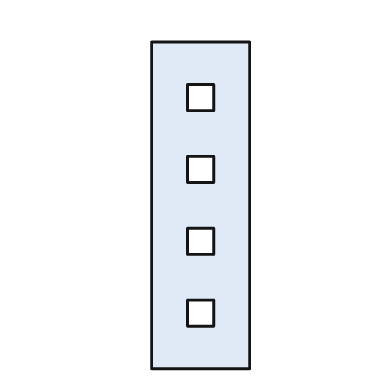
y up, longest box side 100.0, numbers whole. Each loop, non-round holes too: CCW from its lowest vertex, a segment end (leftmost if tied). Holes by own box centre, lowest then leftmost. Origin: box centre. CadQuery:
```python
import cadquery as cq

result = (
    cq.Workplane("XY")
    .moveTo(-15.0, -50.0)
    .lineTo(15.0, -50.0)
    .lineTo(15.0, 50.0)
    .lineTo(-15.0, 50.0)
    .close()
    .moveTo(-4.0, -37.0)
    .lineTo(4.0, -37.0)
    .lineTo(4.0, -29.0)
    .lineTo(-4.0, -29.0)
    .close()
    .moveTo(-4.0, -15.0)
    .lineTo(4.0, -15.0)
    .lineTo(4.0, -7.0)
    .lineTo(-4.0, -7.0)
    .close()
    .moveTo(-4.0, 7.0)
    .lineTo(4.0, 7.0)
    .lineTo(4.0, 15.0)
    .lineTo(-4.0, 15.0)
    .close()
    .moveTo(-4.0, 29.0)
    .lineTo(4.0, 29.0)
    .lineTo(4.0, 37.0)
    .lineTo(-4.0, 37.0)
    .close()
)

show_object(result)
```